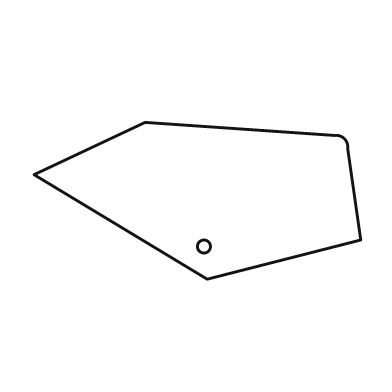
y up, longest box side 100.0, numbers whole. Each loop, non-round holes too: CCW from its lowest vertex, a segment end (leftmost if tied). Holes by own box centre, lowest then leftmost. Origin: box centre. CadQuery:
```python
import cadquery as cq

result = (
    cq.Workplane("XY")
    .moveTo(3.0, -24.0)
    .lineTo(50.0, -12.0)
    .lineTo(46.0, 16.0)
    .threePointArc((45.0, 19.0), (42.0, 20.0))
    .lineTo(-16.0, 24.0)
    .lineTo(-50.0, 8.0)
    .close()
    .moveTo(2.0, -14.0)
    .circle(2.0)
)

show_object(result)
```